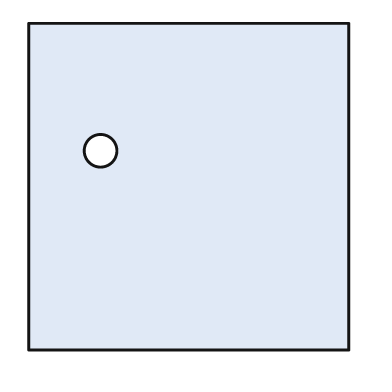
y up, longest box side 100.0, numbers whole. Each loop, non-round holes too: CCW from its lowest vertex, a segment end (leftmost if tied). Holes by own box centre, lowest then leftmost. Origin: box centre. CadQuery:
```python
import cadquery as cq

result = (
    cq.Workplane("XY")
    .moveTo(-49.0, -50.0)
    .lineTo(49.0, -50.0)
    .lineTo(49.0, 50.0)
    .lineTo(-49.0, 50.0)
    .close()
    .moveTo(-27.0, 11.0)
    .circle(5.0)
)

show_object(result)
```